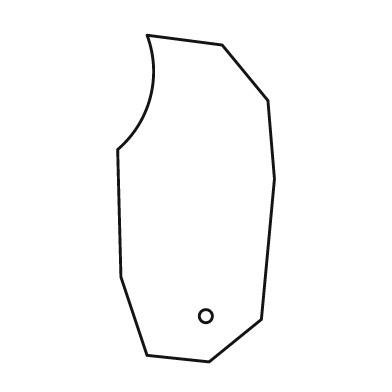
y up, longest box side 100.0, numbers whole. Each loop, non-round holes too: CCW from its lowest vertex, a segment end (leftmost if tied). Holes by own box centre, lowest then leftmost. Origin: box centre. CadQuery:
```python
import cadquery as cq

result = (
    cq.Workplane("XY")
    .moveTo(4.0, -50.0)
    .lineTo(20.0, -37.0)
    .lineTo(24.0, 6.0)
    .lineTo(22.0, 30.0)
    .lineTo(8.0, 47.0)
    .lineTo(-15.0, 50.0)
    .threePointArc((-14.0, 31.0), (-24.0, 15.0))
    .lineTo(-23.0, -24.0)
    .lineTo(-15.0, -48.0)
    .close()
    .moveTo(3.0, -36.0)
    .circle(2.0)
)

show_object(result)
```